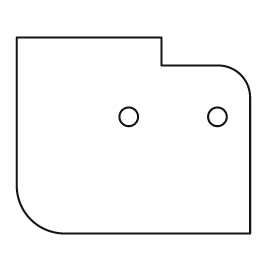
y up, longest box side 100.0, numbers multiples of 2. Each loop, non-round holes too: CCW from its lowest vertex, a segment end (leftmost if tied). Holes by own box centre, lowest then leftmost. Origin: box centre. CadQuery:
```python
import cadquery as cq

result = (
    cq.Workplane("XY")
    .moveTo(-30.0, -42.0)
    .lineTo(50.0, -42.0)
    .lineTo(50.0, 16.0)
    .threePointArc((46.0, 26.0), (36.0, 30.0))
    .lineTo(12.0, 30.0)
    .lineTo(12.0, 42.0)
    .lineTo(-50.0, 42.0)
    .lineTo(-50.0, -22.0)
    .threePointArc((-44.0, -36.0), (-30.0, -42.0))
    .close()
    .moveTo(-2.0, 8.0)
    .circle(4.0)
    .moveTo(36.0, 8.0)
    .circle(4.0)
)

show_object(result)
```